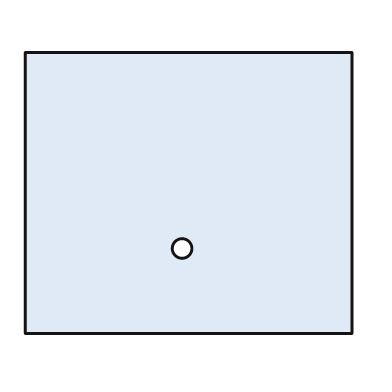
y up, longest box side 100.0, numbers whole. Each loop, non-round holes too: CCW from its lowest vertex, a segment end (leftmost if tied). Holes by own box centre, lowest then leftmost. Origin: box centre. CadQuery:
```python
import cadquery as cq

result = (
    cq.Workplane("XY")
    .moveTo(-50.0, -43.0)
    .lineTo(50.0, -43.0)
    .lineTo(50.0, 43.0)
    .lineTo(-50.0, 43.0)
    .close()
    .moveTo(-2.0, -17.0)
    .circle(3.0)
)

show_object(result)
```